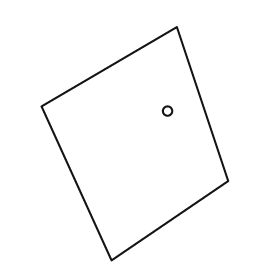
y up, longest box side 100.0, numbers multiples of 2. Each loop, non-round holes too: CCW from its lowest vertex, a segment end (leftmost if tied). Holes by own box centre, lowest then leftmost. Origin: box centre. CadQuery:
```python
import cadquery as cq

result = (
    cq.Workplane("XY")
    .moveTo(-10.0, -50.0)
    .lineTo(40.0, -16.0)
    .lineTo(18.0, 50.0)
    .lineTo(-40.0, 16.0)
    .close()
    .moveTo(14.0, 14.0)
    .circle(2.0)
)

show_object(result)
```